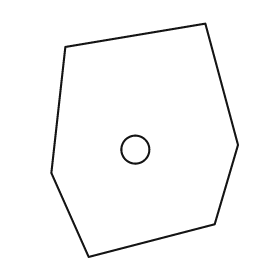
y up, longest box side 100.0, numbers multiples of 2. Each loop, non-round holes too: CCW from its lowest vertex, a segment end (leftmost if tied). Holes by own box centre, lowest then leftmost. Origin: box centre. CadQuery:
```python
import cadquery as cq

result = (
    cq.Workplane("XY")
    .moveTo(-24.0, -50.0)
    .lineTo(30.0, -36.0)
    .lineTo(40.0, -2.0)
    .lineTo(26.0, 50.0)
    .lineTo(-34.0, 40.0)
    .lineTo(-40.0, -14.0)
    .close()
    .moveTo(-4.0, -4.0)
    .circle(6.0)
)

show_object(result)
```